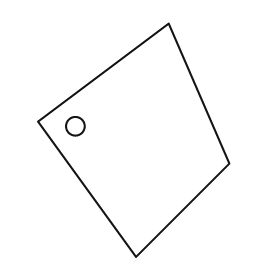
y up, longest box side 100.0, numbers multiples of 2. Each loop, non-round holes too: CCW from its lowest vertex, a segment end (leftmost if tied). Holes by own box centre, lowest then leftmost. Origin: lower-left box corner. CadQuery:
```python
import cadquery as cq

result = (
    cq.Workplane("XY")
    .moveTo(42.0, 0.0)
    .lineTo(82.0, 40.0)
    .lineTo(56.0, 100.0)
    .lineTo(0.0, 58.0)
    .close()
    .moveTo(16.0, 56.0)
    .circle(4.0)
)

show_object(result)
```